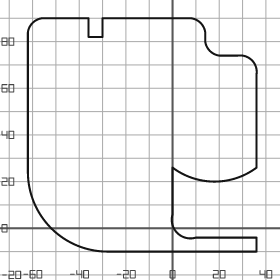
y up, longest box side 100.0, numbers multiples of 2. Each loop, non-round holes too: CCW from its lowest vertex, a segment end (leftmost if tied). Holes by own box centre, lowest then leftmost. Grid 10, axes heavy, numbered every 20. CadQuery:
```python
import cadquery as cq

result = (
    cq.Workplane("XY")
    .moveTo(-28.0, -10.0)
    .lineTo(36.0, -10.0)
    .lineTo(36.0, -4.0)
    .lineTo(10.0, -4.0)
    .threePointArc((2.0, -2.0), (0.0, 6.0))
    .lineTo(0.0, 26.0)
    .threePointArc((18.0, 20.0), (36.0, 26.0))
    .lineTo(36.0, 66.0)
    .threePointArc((34.0, 72.0), (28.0, 74.0))
    .lineTo(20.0, 74.0)
    .threePointArc((16.0, 76.0), (14.0, 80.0))
    .lineTo(14.0, 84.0)
    .threePointArc((12.0, 88.0), (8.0, 90.0))
    .lineTo(-30.0, 90.0)
    .lineTo(-30.0, 82.0)
    .lineTo(-36.0, 82.0)
    .lineTo(-36.0, 90.0)
    .lineTo(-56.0, 90.0)
    .threePointArc((-60.0, 88.0), (-62.0, 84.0))
    .lineTo(-62.0, 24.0)
    .threePointArc((-52.0, 0.0), (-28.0, -10.0))
    .close()
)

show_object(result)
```